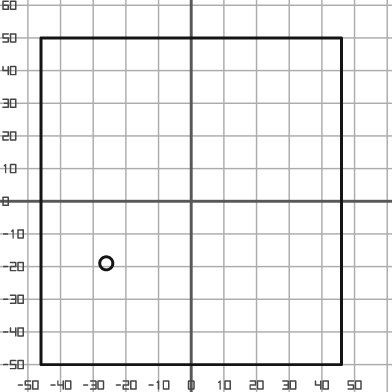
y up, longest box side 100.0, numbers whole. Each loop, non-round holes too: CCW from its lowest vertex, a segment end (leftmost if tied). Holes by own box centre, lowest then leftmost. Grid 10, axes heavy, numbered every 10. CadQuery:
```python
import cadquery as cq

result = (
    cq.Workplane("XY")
    .moveTo(-46.0, -50.0)
    .lineTo(46.0, -50.0)
    .lineTo(46.0, 50.0)
    .lineTo(-46.0, 50.0)
    .close()
    .moveTo(-26.0, -19.0)
    .circle(2.0)
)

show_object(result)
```